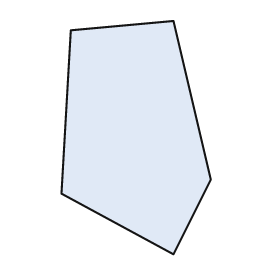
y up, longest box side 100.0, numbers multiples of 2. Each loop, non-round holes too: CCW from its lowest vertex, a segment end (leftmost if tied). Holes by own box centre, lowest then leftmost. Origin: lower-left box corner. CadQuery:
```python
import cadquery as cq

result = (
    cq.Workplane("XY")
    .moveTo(48.0, 0.0)
    .lineTo(64.0, 32.0)
    .lineTo(48.0, 100.0)
    .lineTo(4.0, 96.0)
    .lineTo(0.0, 26.0)
    .close()
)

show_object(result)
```